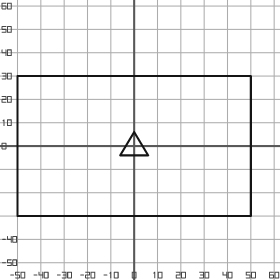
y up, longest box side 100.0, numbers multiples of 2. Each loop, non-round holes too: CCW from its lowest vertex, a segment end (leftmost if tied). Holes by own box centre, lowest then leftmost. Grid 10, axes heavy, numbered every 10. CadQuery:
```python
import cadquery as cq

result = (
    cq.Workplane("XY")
    .moveTo(-50.0, -30.0)
    .lineTo(50.0, -30.0)
    .lineTo(50.0, 30.0)
    .lineTo(-50.0, 30.0)
    .close()
    .moveTo(-6.0, -4.0)
    .lineTo(6.0, -4.0)
    .lineTo(0.0, 6.0)
    .close()
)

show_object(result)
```